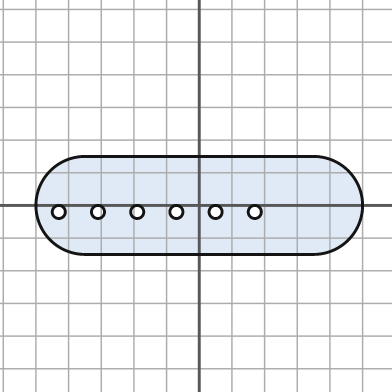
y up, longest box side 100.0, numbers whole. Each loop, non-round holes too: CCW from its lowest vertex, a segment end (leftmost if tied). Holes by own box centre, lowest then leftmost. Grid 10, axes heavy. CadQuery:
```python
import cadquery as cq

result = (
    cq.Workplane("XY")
    .moveTo(-35.0, -15.0)
    .lineTo(35.0, -15.0)
    .threePointArc((50.0, 0.0), (35.0, 15.0))
    .lineTo(-35.0, 15.0)
    .threePointArc((-50.0, 0.0), (-35.0, -15.0))
    .close()
    .moveTo(-43.0, -2.0)
    .circle(2.0)
    .moveTo(-31.0, -2.0)
    .circle(2.0)
    .moveTo(-19.0, -2.0)
    .circle(2.0)
    .moveTo(-7.0, -2.0)
    .circle(2.0)
    .moveTo(5.0, -2.0)
    .circle(2.0)
    .moveTo(17.0, -2.0)
    .circle(2.0)
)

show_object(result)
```